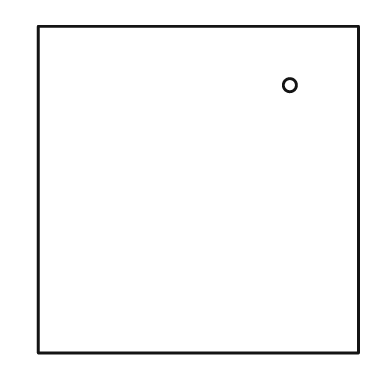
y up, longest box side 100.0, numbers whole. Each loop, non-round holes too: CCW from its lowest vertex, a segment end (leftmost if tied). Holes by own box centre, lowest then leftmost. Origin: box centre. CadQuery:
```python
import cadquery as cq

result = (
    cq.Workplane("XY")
    .moveTo(-49.0, -50.0)
    .lineTo(49.0, -50.0)
    .lineTo(49.0, 50.0)
    .lineTo(-49.0, 50.0)
    .close()
    .moveTo(28.0, 32.0)
    .circle(2.0)
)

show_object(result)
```